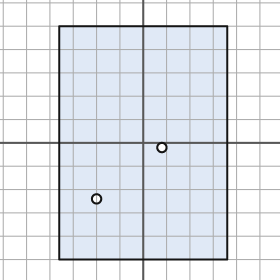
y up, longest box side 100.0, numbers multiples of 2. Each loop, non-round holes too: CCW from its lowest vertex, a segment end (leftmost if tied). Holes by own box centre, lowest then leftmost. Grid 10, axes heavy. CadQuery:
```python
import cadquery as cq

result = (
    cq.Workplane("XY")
    .moveTo(-36.0, -50.0)
    .lineTo(36.0, -50.0)
    .lineTo(36.0, 50.0)
    .lineTo(-36.0, 50.0)
    .close()
    .moveTo(-20.0, -24.0)
    .circle(2.0)
    .moveTo(8.0, -2.0)
    .circle(2.0)
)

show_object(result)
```